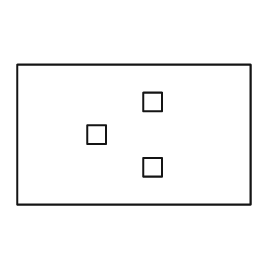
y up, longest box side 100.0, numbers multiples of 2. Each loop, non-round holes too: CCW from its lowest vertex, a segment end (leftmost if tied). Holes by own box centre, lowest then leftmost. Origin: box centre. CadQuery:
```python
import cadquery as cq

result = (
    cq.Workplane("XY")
    .moveTo(-50.0, -30.0)
    .lineTo(50.0, -30.0)
    .lineTo(50.0, 30.0)
    .lineTo(-50.0, 30.0)
    .close()
    .moveTo(4.0, -18.0)
    .lineTo(12.0, -18.0)
    .lineTo(12.0, -10.0)
    .lineTo(4.0, -10.0)
    .close()
    .moveTo(-20.0, -4.0)
    .lineTo(-12.0, -4.0)
    .lineTo(-12.0, 4.0)
    .lineTo(-20.0, 4.0)
    .close()
    .moveTo(4.0, 10.0)
    .lineTo(12.0, 10.0)
    .lineTo(12.0, 18.0)
    .lineTo(4.0, 18.0)
    .close()
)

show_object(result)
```